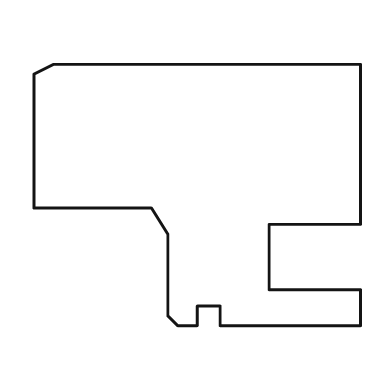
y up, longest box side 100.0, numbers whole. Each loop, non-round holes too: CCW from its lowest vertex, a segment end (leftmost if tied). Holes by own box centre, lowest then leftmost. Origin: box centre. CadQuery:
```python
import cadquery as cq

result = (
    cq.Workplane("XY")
    .moveTo(-6.0, -40.0)
    .lineTo(0.0, -40.0)
    .lineTo(0.0, -34.0)
    .lineTo(7.0, -34.0)
    .lineTo(7.0, -40.0)
    .lineTo(50.0, -40.0)
    .lineTo(50.0, -29.0)
    .lineTo(22.0, -29.0)
    .lineTo(22.0, -9.0)
    .lineTo(50.0, -9.0)
    .lineTo(50.0, 40.0)
    .lineTo(-44.0, 40.0)
    .lineTo(-50.0, 37.0)
    .lineTo(-50.0, -4.0)
    .lineTo(-14.0, -4.0)
    .lineTo(-9.0, -12.0)
    .lineTo(-9.0, -37.0)
    .close()
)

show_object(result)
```